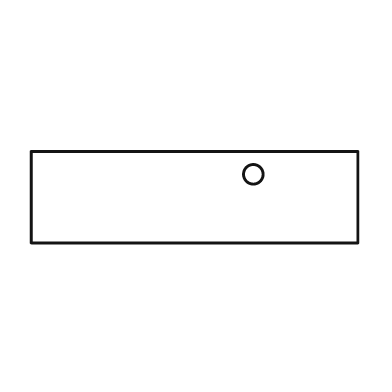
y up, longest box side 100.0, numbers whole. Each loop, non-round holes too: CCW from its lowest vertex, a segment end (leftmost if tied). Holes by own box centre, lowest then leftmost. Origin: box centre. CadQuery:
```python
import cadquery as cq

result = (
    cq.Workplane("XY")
    .moveTo(-50.0, -14.0)
    .lineTo(50.0, -14.0)
    .lineTo(50.0, 14.0)
    .lineTo(-50.0, 14.0)
    .close()
    .moveTo(18.0, 7.0)
    .circle(3.0)
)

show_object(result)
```